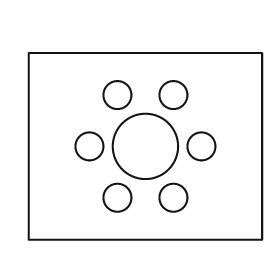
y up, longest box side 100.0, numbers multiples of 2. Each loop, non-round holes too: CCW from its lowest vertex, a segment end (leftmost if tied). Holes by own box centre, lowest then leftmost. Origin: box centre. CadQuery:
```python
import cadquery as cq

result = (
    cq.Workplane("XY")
    .moveTo(-50.0, -40.0)
    .lineTo(50.0, -40.0)
    .lineTo(50.0, 40.0)
    .lineTo(-50.0, 40.0)
    .close()
    .moveTo(-12.0, -22.0)
    .circle(6.0)
    .moveTo(12.0, -22.0)
    .circle(6.0)
    .moveTo(-24.0, 0.0)
    .circle(6.0)
    .moveTo(0.0, 0.0)
    .circle(14.0)
    .moveTo(24.0, 0.0)
    .circle(6.0)
    .moveTo(-12.0, 22.0)
    .circle(6.0)
    .moveTo(12.0, 22.0)
    .circle(6.0)
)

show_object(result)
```